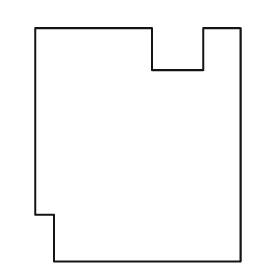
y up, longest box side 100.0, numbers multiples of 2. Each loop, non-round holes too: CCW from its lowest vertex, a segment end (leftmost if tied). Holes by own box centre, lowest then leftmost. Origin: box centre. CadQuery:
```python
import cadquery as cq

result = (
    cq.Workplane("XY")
    .moveTo(-36.0, -50.0)
    .lineTo(44.0, -50.0)
    .lineTo(44.0, 50.0)
    .lineTo(28.0, 50.0)
    .lineTo(28.0, 32.0)
    .lineTo(6.0, 32.0)
    .lineTo(6.0, 50.0)
    .lineTo(-44.0, 50.0)
    .lineTo(-44.0, -30.0)
    .lineTo(-36.0, -30.0)
    .close()
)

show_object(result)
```